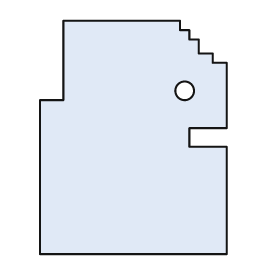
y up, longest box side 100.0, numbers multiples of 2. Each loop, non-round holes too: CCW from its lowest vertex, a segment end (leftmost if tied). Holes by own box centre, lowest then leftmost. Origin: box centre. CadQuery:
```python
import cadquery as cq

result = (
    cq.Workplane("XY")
    .moveTo(-40.0, -50.0)
    .lineTo(40.0, -50.0)
    .lineTo(40.0, -4.0)
    .lineTo(24.0, -4.0)
    .lineTo(24.0, 4.0)
    .lineTo(40.0, 4.0)
    .lineTo(40.0, 32.0)
    .lineTo(34.0, 32.0)
    .lineTo(34.0, 36.0)
    .lineTo(28.0, 36.0)
    .lineTo(28.0, 42.0)
    .lineTo(24.0, 42.0)
    .lineTo(24.0, 46.0)
    .lineTo(20.0, 46.0)
    .lineTo(20.0, 50.0)
    .lineTo(-30.0, 50.0)
    .lineTo(-30.0, 16.0)
    .lineTo(-40.0, 16.0)
    .close()
    .moveTo(22.0, 20.0)
    .circle(4.0)
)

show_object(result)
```